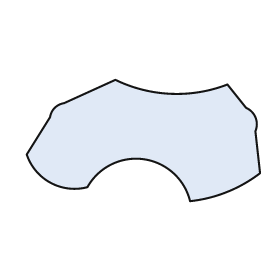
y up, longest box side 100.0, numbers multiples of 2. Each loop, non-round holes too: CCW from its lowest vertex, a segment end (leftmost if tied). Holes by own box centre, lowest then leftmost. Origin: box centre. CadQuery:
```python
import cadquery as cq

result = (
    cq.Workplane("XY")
    .moveTo(20.0, -26.0)
    .threePointArc((36.0, -22.0), (50.0, -14.0))
    .lineTo(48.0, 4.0)
    .threePointArc((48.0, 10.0), (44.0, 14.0))
    .lineTo(36.0, 24.0)
    .threePointArc((12.0, 20.0), (-12.0, 26.0))
    .lineTo(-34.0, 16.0)
    .threePointArc((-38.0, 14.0), (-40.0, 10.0))
    .lineTo(-50.0, -6.0)
    .threePointArc((-40.0, -18.0), (-24.0, -20.0))
    .threePointArc((0.0, -8.0), (20.0, -26.0))
    .close()
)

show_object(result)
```